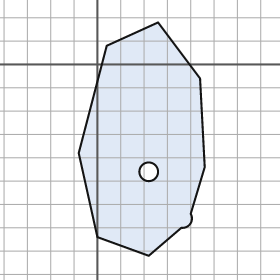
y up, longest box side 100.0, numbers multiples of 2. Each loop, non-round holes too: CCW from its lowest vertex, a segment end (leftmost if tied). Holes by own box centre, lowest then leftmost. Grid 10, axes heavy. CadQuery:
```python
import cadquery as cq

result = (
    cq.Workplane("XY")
    .moveTo(22.0, -82.0)
    .lineTo(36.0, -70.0)
    .threePointArc((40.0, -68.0), (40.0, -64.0))
    .lineTo(46.0, -44.0)
    .lineTo(44.0, -6.0)
    .lineTo(26.0, 18.0)
    .lineTo(4.0, 8.0)
    .lineTo(-8.0, -38.0)
    .lineTo(0.0, -74.0)
    .close()
    .moveTo(22.0, -46.0)
    .circle(4.0)
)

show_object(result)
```